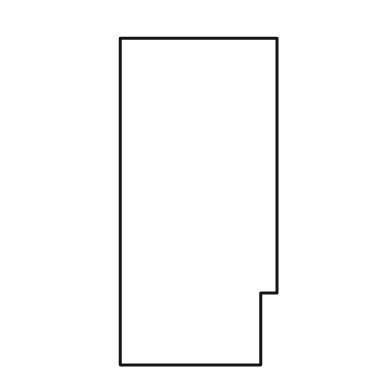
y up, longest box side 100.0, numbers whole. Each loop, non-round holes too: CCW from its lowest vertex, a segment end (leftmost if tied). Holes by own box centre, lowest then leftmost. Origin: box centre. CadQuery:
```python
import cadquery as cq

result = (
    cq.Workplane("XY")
    .moveTo(-24.0, -50.0)
    .lineTo(19.0, -50.0)
    .lineTo(19.0, -28.0)
    .lineTo(24.0, -28.0)
    .lineTo(24.0, 50.0)
    .lineTo(-24.0, 50.0)
    .close()
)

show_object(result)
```